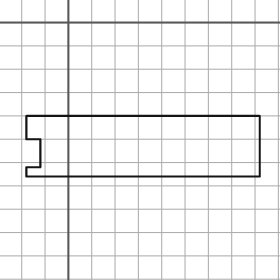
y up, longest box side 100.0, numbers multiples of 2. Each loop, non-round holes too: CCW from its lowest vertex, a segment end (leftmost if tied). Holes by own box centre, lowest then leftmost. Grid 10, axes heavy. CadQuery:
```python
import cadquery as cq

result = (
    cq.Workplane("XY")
    .moveTo(-18.0, -66.0)
    .lineTo(82.0, -66.0)
    .lineTo(82.0, -40.0)
    .lineTo(-18.0, -40.0)
    .lineTo(-18.0, -50.0)
    .lineTo(-12.0, -50.0)
    .lineTo(-12.0, -62.0)
    .lineTo(-18.0, -62.0)
    .close()
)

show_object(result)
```